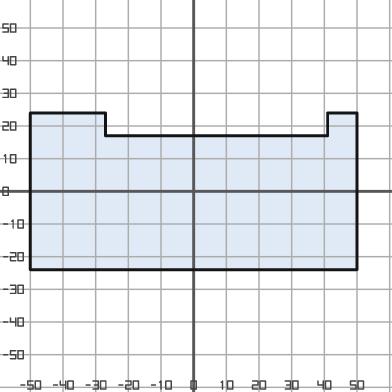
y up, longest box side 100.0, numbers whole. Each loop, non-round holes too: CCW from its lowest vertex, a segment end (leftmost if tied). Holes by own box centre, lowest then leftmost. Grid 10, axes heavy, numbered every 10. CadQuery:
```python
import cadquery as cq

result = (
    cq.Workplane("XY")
    .moveTo(-50.0, -24.0)
    .lineTo(50.0, -24.0)
    .lineTo(50.0, 24.0)
    .lineTo(41.0, 24.0)
    .lineTo(41.0, 17.0)
    .lineTo(-27.0, 17.0)
    .lineTo(-27.0, 24.0)
    .lineTo(-50.0, 24.0)
    .close()
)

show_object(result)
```